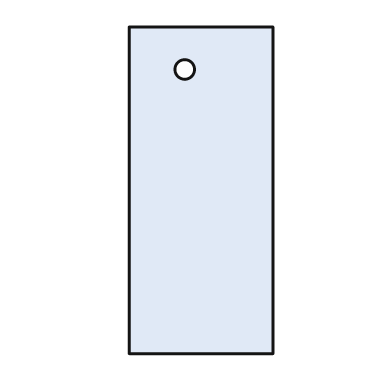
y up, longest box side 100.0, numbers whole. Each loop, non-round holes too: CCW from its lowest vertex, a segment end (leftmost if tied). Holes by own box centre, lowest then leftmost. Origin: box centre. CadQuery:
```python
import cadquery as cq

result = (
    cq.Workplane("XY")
    .moveTo(-22.0, -50.0)
    .lineTo(22.0, -50.0)
    .lineTo(22.0, 50.0)
    .lineTo(-22.0, 50.0)
    .close()
    .moveTo(-5.0, 37.0)
    .circle(3.0)
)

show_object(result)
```